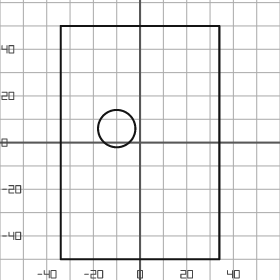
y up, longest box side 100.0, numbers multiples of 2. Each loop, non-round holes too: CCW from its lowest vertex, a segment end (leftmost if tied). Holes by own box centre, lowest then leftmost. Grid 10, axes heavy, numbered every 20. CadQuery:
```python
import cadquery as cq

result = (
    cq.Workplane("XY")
    .moveTo(-34.0, -50.0)
    .lineTo(34.0, -50.0)
    .lineTo(34.0, 50.0)
    .lineTo(-34.0, 50.0)
    .close()
    .moveTo(-10.0, 6.0)
    .circle(8.0)
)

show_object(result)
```